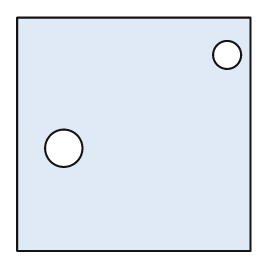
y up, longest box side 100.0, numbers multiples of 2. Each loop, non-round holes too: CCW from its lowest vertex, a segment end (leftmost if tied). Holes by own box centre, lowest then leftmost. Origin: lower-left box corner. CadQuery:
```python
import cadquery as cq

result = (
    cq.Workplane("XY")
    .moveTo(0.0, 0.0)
    .lineTo(100.0, 0.0)
    .lineTo(100.0, 100.0)
    .lineTo(0.0, 100.0)
    .close()
    .moveTo(20.0, 44.0)
    .circle(8.0)
    .moveTo(90.0, 84.0)
    .circle(6.0)
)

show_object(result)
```